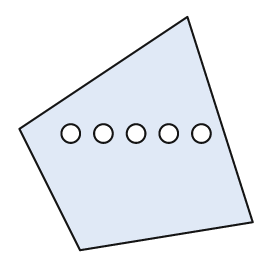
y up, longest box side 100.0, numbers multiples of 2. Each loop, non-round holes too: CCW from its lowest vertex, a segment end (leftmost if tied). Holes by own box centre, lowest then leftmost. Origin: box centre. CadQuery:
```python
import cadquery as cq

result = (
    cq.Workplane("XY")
    .moveTo(-24.0, -50.0)
    .lineTo(50.0, -38.0)
    .lineTo(22.0, 50.0)
    .lineTo(-50.0, 2.0)
    .close()
    .moveTo(-28.0, 0.0)
    .circle(4.0)
    .moveTo(-14.0, 0.0)
    .circle(4.0)
    .moveTo(0.0, 0.0)
    .circle(4.0)
    .moveTo(14.0, 0.0)
    .circle(4.0)
    .moveTo(28.0, 0.0)
    .circle(4.0)
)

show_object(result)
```